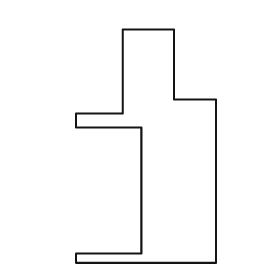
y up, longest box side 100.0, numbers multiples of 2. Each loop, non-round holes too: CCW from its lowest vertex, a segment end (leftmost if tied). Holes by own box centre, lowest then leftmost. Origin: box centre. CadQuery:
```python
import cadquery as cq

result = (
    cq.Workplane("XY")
    .moveTo(-30.0, -50.0)
    .lineTo(30.0, -50.0)
    .lineTo(30.0, 20.0)
    .lineTo(12.0, 20.0)
    .lineTo(12.0, 50.0)
    .lineTo(-10.0, 50.0)
    .lineTo(-10.0, 14.0)
    .lineTo(-30.0, 14.0)
    .lineTo(-30.0, 8.0)
    .lineTo(-2.0, 8.0)
    .lineTo(-2.0, -46.0)
    .lineTo(-30.0, -46.0)
    .close()
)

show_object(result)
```